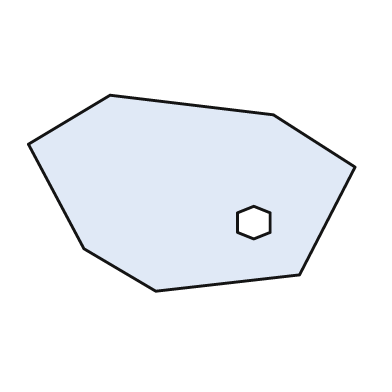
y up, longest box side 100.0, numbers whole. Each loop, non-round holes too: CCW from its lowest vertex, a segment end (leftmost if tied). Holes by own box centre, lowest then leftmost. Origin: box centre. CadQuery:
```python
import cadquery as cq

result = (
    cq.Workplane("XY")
    .moveTo(-11.0, -30.0)
    .lineTo(33.0, -25.0)
    .lineTo(50.0, 8.0)
    .lineTo(25.0, 24.0)
    .lineTo(-25.0, 30.0)
    .lineTo(-50.0, 15.0)
    .lineTo(-33.0, -17.0)
    .close()
    .moveTo(19.0, -14.0)
    .lineTo(24.0, -12.0)
    .lineTo(24.0, -6.0)
    .lineTo(19.0, -4.0)
    .lineTo(14.0, -6.0)
    .lineTo(14.0, -12.0)
    .close()
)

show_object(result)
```